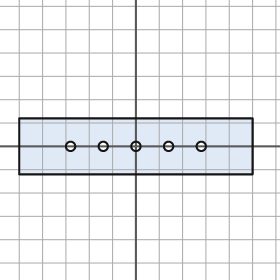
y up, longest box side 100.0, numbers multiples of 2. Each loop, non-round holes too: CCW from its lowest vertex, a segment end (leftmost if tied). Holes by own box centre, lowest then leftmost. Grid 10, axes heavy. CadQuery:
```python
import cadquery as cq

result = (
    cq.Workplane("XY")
    .moveTo(-50.0, -12.0)
    .lineTo(50.0, -12.0)
    .lineTo(50.0, 12.0)
    .lineTo(-50.0, 12.0)
    .close()
    .moveTo(-28.0, 0.0)
    .circle(2.0)
    .moveTo(-14.0, 0.0)
    .circle(2.0)
    .moveTo(0.0, 0.0)
    .circle(2.0)
    .moveTo(14.0, 0.0)
    .circle(2.0)
    .moveTo(28.0, 0.0)
    .circle(2.0)
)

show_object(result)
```